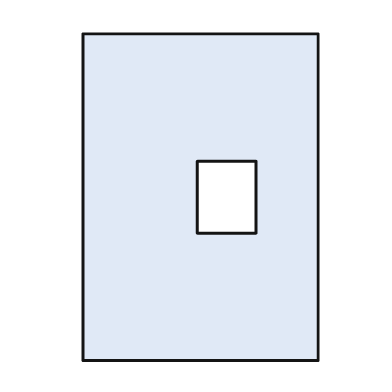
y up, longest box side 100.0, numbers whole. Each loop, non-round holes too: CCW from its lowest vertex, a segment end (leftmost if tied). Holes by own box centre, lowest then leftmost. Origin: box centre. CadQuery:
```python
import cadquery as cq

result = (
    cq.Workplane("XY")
    .moveTo(-36.0, -50.0)
    .lineTo(36.0, -50.0)
    .lineTo(36.0, 50.0)
    .lineTo(-36.0, 50.0)
    .close()
    .moveTo(-1.0, -11.0)
    .lineTo(17.0, -11.0)
    .lineTo(17.0, 11.0)
    .lineTo(-1.0, 11.0)
    .close()
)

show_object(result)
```